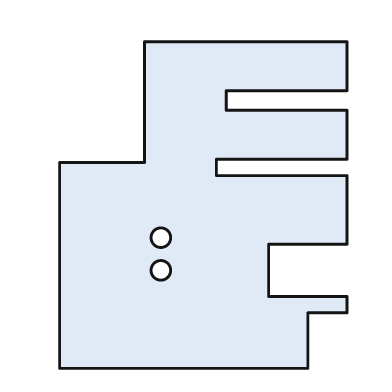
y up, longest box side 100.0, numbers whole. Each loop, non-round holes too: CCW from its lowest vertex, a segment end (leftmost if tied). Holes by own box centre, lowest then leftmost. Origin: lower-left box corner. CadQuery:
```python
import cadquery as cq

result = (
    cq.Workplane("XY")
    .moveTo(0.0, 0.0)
    .lineTo(76.0, 0.0)
    .lineTo(76.0, 17.0)
    .lineTo(88.0, 17.0)
    .lineTo(88.0, 22.0)
    .lineTo(64.0, 22.0)
    .lineTo(64.0, 38.0)
    .lineTo(88.0, 38.0)
    .lineTo(88.0, 59.0)
    .lineTo(48.0, 59.0)
    .lineTo(48.0, 64.0)
    .lineTo(88.0, 64.0)
    .lineTo(88.0, 79.0)
    .lineTo(51.0, 79.0)
    .lineTo(51.0, 85.0)
    .lineTo(88.0, 85.0)
    .lineTo(88.0, 100.0)
    .lineTo(26.0, 100.0)
    .lineTo(26.0, 63.0)
    .lineTo(0.0, 63.0)
    .close()
    .moveTo(31.0, 30.0)
    .circle(3.0)
    .moveTo(31.0, 40.0)
    .circle(3.0)
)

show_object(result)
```